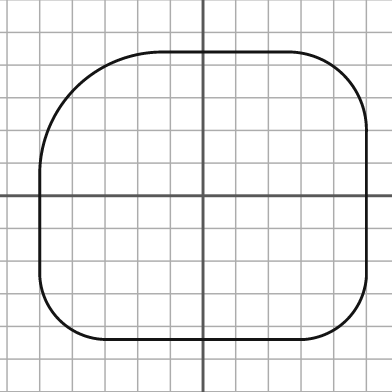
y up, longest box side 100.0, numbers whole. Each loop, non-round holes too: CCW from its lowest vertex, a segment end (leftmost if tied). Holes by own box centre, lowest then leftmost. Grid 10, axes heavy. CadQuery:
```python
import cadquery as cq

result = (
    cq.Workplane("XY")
    .moveTo(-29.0, -44.0)
    .lineTo(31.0, -44.0)
    .threePointArc((44.0, -38.0), (50.0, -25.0))
    .lineTo(50.0, 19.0)
    .threePointArc((43.0, 37.0), (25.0, 44.0))
    .lineTo(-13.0, 44.0)
    .threePointArc((-39.0, 33.0), (-50.0, 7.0))
    .lineTo(-50.0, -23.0)
    .threePointArc((-44.0, -38.0), (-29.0, -44.0))
    .close()
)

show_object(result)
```